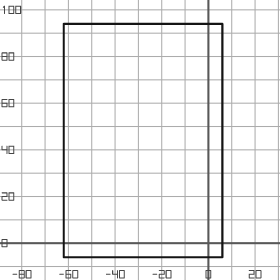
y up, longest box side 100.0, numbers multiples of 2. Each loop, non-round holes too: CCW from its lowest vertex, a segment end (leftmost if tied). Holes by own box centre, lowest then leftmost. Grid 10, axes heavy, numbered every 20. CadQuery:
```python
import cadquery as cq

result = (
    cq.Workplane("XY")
    .moveTo(-62.0, -6.0)
    .lineTo(6.0, -6.0)
    .lineTo(6.0, 94.0)
    .lineTo(-62.0, 94.0)
    .close()
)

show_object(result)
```